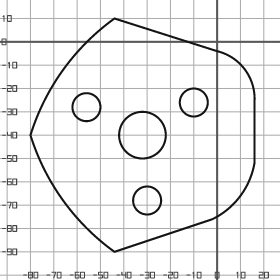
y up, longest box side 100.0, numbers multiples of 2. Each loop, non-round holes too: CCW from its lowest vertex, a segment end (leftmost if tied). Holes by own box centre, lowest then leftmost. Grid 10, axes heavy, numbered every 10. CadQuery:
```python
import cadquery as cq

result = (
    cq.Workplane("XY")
    .moveTo(-44.0, -90.0)
    .lineTo(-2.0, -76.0)
    .threePointArc((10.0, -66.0), (16.0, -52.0))
    .lineTo(16.0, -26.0)
    .threePointArc((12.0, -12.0), (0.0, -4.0))
    .lineTo(-44.0, 10.0)
    .threePointArc((-66.0, -12.0), (-80.0, -40.0))
    .threePointArc((-66.0, -68.0), (-44.0, -90.0))
    .close()
    .moveTo(-30.0, -68.0)
    .circle(6.0)
    .moveTo(-32.0, -40.0)
    .circle(10.0)
    .moveTo(-56.0, -28.0)
    .circle(6.0)
    .moveTo(-10.0, -26.0)
    .circle(6.0)
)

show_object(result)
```